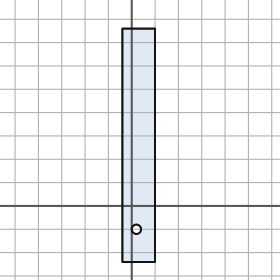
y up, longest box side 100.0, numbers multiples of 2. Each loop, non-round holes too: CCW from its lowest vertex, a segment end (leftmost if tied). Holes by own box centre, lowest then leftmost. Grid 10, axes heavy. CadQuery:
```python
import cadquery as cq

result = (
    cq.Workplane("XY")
    .moveTo(-4.0, -24.0)
    .lineTo(10.0, -24.0)
    .lineTo(10.0, 76.0)
    .lineTo(-4.0, 76.0)
    .close()
    .moveTo(2.0, -10.0)
    .circle(2.0)
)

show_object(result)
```